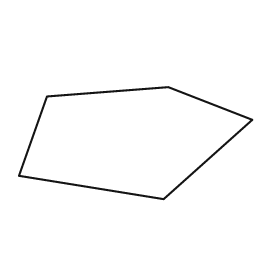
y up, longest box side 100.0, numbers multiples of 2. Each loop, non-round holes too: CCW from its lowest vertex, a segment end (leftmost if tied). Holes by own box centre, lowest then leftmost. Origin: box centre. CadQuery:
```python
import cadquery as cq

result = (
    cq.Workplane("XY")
    .moveTo(12.0, -24.0)
    .lineTo(50.0, 10.0)
    .lineTo(14.0, 24.0)
    .lineTo(-38.0, 20.0)
    .lineTo(-50.0, -14.0)
    .close()
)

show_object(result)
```